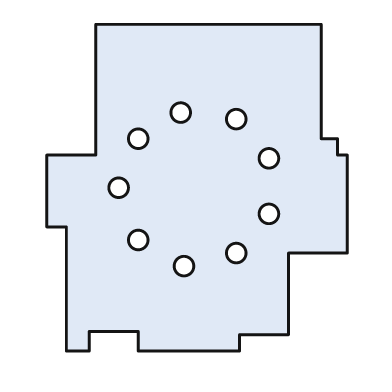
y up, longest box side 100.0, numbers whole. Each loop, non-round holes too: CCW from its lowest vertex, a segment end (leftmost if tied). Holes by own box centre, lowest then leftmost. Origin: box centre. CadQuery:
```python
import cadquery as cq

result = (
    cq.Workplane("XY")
    .moveTo(-40.0, -50.0)
    .lineTo(-33.0, -50.0)
    .lineTo(-33.0, -44.0)
    .lineTo(-18.0, -44.0)
    .lineTo(-18.0, -50.0)
    .lineTo(13.0, -50.0)
    .lineTo(13.0, -45.0)
    .lineTo(28.0, -45.0)
    .lineTo(28.0, -20.0)
    .lineTo(46.0, -20.0)
    .lineTo(46.0, 10.0)
    .lineTo(43.0, 10.0)
    .lineTo(43.0, 15.0)
    .lineTo(38.0, 15.0)
    .lineTo(38.0, 50.0)
    .lineTo(-31.0, 50.0)
    .lineTo(-31.0, 10.0)
    .lineTo(-46.0, 10.0)
    .lineTo(-46.0, -12.0)
    .lineTo(-40.0, -12.0)
    .close()
    .moveTo(-4.0, -24.0)
    .circle(3.0)
    .moveTo(12.0, -20.0)
    .circle(3.0)
    .moveTo(-18.0, -16.0)
    .circle(3.0)
    .moveTo(22.0, -8.0)
    .circle(3.0)
    .moveTo(-24.0, 0.0)
    .circle(3.0)
    .moveTo(22.0, 9.0)
    .circle(3.0)
    .moveTo(-18.0, 15.0)
    .circle(3.0)
    .moveTo(12.0, 21.0)
    .circle(3.0)
    .moveTo(-5.0, 23.0)
    .circle(3.0)
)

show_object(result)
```